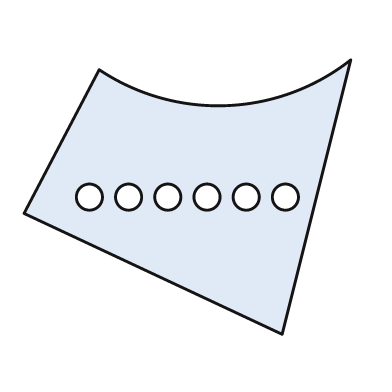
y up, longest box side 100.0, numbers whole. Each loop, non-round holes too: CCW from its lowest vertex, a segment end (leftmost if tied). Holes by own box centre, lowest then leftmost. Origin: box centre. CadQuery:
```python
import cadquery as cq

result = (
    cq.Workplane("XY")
    .moveTo(29.0, -42.0)
    .lineTo(50.0, 42.0)
    .threePointArc((12.0, 28.0), (-27.0, 39.0))
    .lineTo(-50.0, -5.0)
    .close()
    .moveTo(-30.0, 0.0)
    .circle(4.0)
    .moveTo(-18.0, 0.0)
    .circle(4.0)
    .moveTo(-6.0, 0.0)
    .circle(4.0)
    .moveTo(6.0, 0.0)
    .circle(4.0)
    .moveTo(18.0, 0.0)
    .circle(4.0)
    .moveTo(30.0, 0.0)
    .circle(4.0)
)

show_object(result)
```